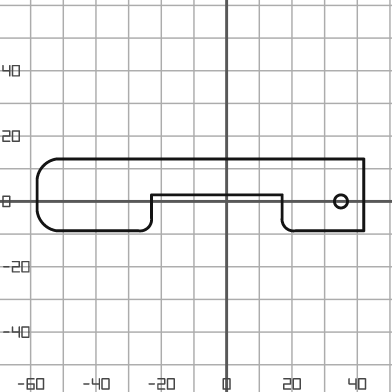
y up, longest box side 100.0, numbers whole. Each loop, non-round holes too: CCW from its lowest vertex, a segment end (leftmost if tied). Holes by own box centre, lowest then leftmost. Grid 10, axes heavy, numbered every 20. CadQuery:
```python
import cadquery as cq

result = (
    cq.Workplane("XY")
    .moveTo(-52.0, -9.0)
    .lineTo(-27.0, -9.0)
    .threePointArc((-24.0, -8.0), (-23.0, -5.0))
    .lineTo(-23.0, 2.0)
    .lineTo(17.0, 2.0)
    .lineTo(17.0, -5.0)
    .threePointArc((18.0, -8.0), (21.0, -9.0))
    .lineTo(42.0, -9.0)
    .lineTo(42.0, 13.0)
    .lineTo(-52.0, 13.0)
    .threePointArc((-56.0, 11.0), (-58.0, 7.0))
    .lineTo(-58.0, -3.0)
    .threePointArc((-56.0, -7.0), (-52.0, -9.0))
    .close()
    .moveTo(35.0, 0.0)
    .circle(2.0)
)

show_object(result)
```